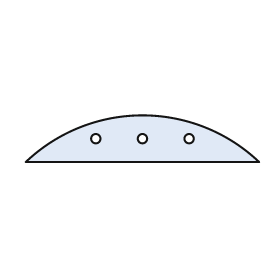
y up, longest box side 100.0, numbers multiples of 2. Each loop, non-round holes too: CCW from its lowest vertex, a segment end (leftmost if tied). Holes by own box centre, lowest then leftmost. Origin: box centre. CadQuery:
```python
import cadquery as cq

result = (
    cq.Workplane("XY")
    .moveTo(-50.0, -10.0)
    .lineTo(50.0, -10.0)
    .threePointArc((0.0, 10.0), (-50.0, -10.0))
    .close()
    .moveTo(-20.0, 0.0)
    .circle(2.0)
    .moveTo(0.0, 0.0)
    .circle(2.0)
    .moveTo(20.0, 0.0)
    .circle(2.0)
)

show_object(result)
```